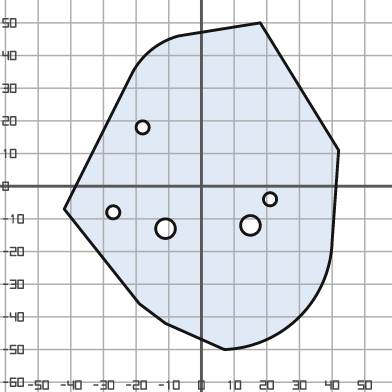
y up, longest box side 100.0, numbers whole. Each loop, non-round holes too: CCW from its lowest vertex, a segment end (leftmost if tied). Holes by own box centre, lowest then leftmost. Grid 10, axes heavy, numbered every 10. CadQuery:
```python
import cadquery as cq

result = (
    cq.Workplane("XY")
    .moveTo(7.0, -50.0)
    .threePointArc((30.0, -40.0), (40.0, -17.0))
    .lineTo(42.0, 11.0)
    .lineTo(18.0, 50.0)
    .lineTo(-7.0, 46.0)
    .threePointArc((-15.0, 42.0), (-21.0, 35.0))
    .lineTo(-42.0, -7.0)
    .lineTo(-19.0, -36.0)
    .lineTo(-11.0, -42.0)
    .close()
    .moveTo(-11.0, -13.0)
    .circle(3.0)
    .moveTo(15.0, -12.0)
    .circle(3.0)
    .moveTo(-27.0, -8.0)
    .circle(2.0)
    .moveTo(21.0, -4.0)
    .circle(2.0)
    .moveTo(-18.0, 18.0)
    .circle(2.0)
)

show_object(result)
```